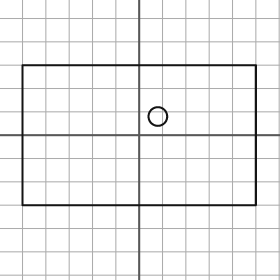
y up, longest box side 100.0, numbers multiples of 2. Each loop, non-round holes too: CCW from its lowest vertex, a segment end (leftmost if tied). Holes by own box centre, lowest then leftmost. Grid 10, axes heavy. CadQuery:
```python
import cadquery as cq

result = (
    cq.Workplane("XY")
    .moveTo(-50.0, -30.0)
    .lineTo(50.0, -30.0)
    .lineTo(50.0, 30.0)
    .lineTo(-50.0, 30.0)
    .close()
    .moveTo(8.0, 8.0)
    .circle(4.0)
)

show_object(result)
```